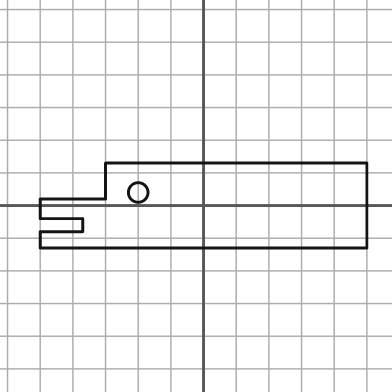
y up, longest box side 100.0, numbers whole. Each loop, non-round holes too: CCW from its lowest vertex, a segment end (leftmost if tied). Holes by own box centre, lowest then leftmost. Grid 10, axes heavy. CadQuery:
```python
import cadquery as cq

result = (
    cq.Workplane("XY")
    .moveTo(-50.0, -13.0)
    .lineTo(50.0, -13.0)
    .lineTo(50.0, 13.0)
    .lineTo(-30.0, 13.0)
    .lineTo(-30.0, 2.0)
    .lineTo(-50.0, 2.0)
    .lineTo(-50.0, -4.0)
    .lineTo(-37.0, -4.0)
    .lineTo(-37.0, -8.0)
    .lineTo(-50.0, -8.0)
    .close()
    .moveTo(-20.0, 4.0)
    .circle(3.0)
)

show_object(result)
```